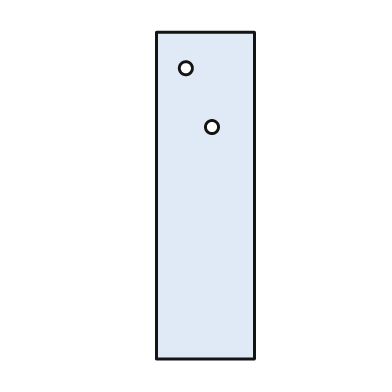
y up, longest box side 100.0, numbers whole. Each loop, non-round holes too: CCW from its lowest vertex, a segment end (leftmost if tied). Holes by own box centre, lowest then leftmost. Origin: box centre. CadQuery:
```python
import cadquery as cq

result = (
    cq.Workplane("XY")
    .moveTo(-15.0, -50.0)
    .lineTo(15.0, -50.0)
    .lineTo(15.0, 50.0)
    .lineTo(-15.0, 50.0)
    .close()
    .moveTo(2.0, 21.0)
    .circle(2.0)
    .moveTo(-6.0, 39.0)
    .circle(2.0)
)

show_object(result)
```